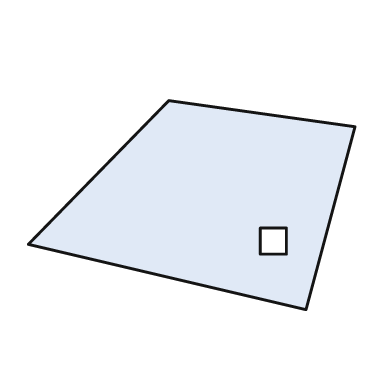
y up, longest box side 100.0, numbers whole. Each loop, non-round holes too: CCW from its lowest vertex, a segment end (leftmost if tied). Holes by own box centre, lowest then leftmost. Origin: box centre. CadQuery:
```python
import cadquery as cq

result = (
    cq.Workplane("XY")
    .moveTo(35.0, -32.0)
    .lineTo(50.0, 24.0)
    .lineTo(-7.0, 32.0)
    .lineTo(-50.0, -12.0)
    .close()
    .moveTo(21.0, -15.0)
    .lineTo(29.0, -15.0)
    .lineTo(29.0, -7.0)
    .lineTo(21.0, -7.0)
    .close()
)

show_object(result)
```